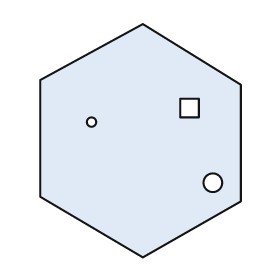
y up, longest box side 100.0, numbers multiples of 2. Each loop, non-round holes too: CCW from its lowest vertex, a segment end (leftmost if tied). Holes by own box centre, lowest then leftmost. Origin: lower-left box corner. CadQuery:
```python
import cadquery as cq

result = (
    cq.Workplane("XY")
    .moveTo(44.0, 0.0)
    .lineTo(86.0, 24.0)
    .lineTo(86.0, 74.0)
    .lineTo(44.0, 100.0)
    .lineTo(0.0, 76.0)
    .lineTo(0.0, 26.0)
    .close()
    .moveTo(74.0, 32.0)
    .circle(4.0)
    .moveTo(22.0, 58.0)
    .circle(2.0)
    .moveTo(60.0, 60.0)
    .lineTo(68.0, 60.0)
    .lineTo(68.0, 68.0)
    .lineTo(60.0, 68.0)
    .close()
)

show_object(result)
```